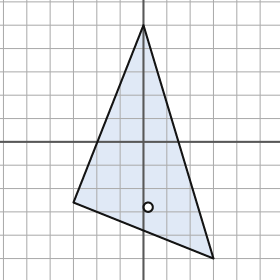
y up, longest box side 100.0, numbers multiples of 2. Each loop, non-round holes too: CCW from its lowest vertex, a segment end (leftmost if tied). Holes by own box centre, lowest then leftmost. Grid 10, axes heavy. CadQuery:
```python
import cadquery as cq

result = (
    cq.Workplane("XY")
    .moveTo(30.0, -50.0)
    .lineTo(0.0, 50.0)
    .lineTo(-30.0, -26.0)
    .close()
    .moveTo(2.0, -28.0)
    .circle(2.0)
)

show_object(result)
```